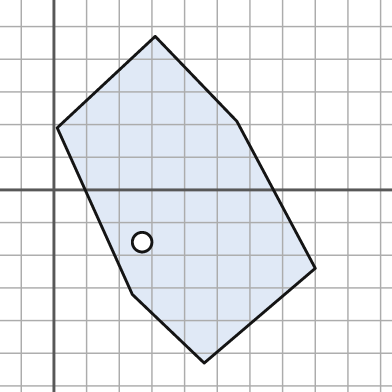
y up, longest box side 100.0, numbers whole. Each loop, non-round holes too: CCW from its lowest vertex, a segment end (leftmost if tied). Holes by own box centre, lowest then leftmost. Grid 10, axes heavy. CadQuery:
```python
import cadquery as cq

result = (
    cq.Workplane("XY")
    .moveTo(46.0, -53.0)
    .lineTo(80.0, -24.0)
    .lineTo(56.0, 21.0)
    .lineTo(31.0, 47.0)
    .lineTo(1.0, 19.0)
    .lineTo(24.0, -32.0)
    .close()
    .moveTo(27.0, -16.0)
    .circle(3.0)
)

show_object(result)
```